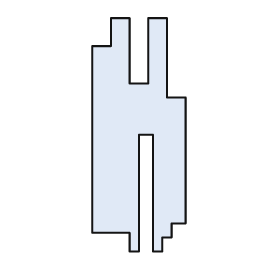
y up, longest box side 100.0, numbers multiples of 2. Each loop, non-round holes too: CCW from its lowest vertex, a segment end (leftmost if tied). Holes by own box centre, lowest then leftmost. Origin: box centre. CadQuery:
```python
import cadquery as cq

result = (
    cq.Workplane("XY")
    .moveTo(-4.0, -50.0)
    .lineTo(0.0, -50.0)
    .lineTo(0.0, 0.0)
    .lineTo(6.0, 0.0)
    .lineTo(6.0, -50.0)
    .lineTo(10.0, -50.0)
    .lineTo(10.0, -44.0)
    .lineTo(14.0, -44.0)
    .lineTo(14.0, -38.0)
    .lineTo(20.0, -38.0)
    .lineTo(20.0, 16.0)
    .lineTo(12.0, 16.0)
    .lineTo(12.0, 50.0)
    .lineTo(4.0, 50.0)
    .lineTo(4.0, 22.0)
    .lineTo(-4.0, 22.0)
    .lineTo(-4.0, 50.0)
    .lineTo(-12.0, 50.0)
    .lineTo(-12.0, 38.0)
    .lineTo(-20.0, 38.0)
    .lineTo(-20.0, -42.0)
    .lineTo(-4.0, -42.0)
    .close()
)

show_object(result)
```